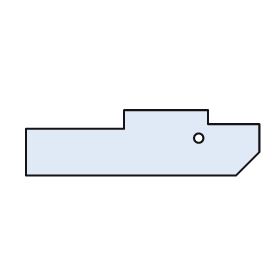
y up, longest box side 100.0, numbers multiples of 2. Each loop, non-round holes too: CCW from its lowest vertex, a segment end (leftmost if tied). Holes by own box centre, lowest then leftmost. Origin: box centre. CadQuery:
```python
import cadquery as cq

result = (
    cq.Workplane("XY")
    .moveTo(-50.0, -14.0)
    .lineTo(40.0, -14.0)
    .lineTo(50.0, -4.0)
    .lineTo(50.0, 8.0)
    .lineTo(28.0, 8.0)
    .lineTo(28.0, 14.0)
    .lineTo(-8.0, 14.0)
    .lineTo(-8.0, 6.0)
    .lineTo(-50.0, 6.0)
    .close()
    .moveTo(24.0, 2.0)
    .circle(2.0)
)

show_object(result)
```